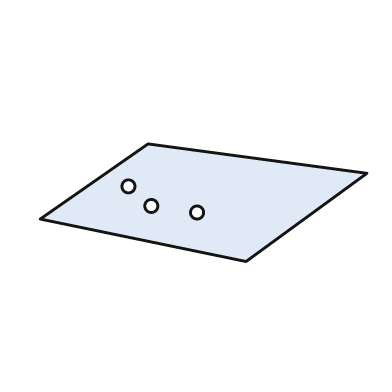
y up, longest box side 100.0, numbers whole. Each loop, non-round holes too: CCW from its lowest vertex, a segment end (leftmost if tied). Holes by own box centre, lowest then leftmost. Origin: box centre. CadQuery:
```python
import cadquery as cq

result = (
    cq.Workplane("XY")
    .moveTo(13.0, -18.0)
    .lineTo(50.0, 9.0)
    .lineTo(-17.0, 18.0)
    .lineTo(-50.0, -5.0)
    .close()
    .moveTo(-2.0, -3.0)
    .circle(2.0)
    .moveTo(-16.0, -1.0)
    .circle(2.0)
    .moveTo(-23.0, 5.0)
    .circle(2.0)
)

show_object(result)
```